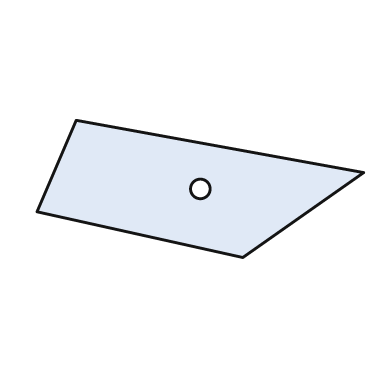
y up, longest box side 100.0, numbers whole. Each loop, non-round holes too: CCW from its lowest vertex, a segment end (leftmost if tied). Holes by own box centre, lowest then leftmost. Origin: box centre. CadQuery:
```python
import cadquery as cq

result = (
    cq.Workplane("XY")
    .moveTo(13.0, -21.0)
    .lineTo(50.0, 5.0)
    .lineTo(-38.0, 21.0)
    .lineTo(-50.0, -7.0)
    .close()
    .moveTo(0.0, 0.0)
    .circle(3.0)
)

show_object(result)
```